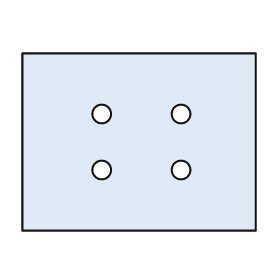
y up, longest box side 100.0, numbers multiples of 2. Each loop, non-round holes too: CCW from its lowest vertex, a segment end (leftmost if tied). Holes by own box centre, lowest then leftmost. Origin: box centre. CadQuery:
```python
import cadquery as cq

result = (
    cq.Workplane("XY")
    .moveTo(-50.0, -38.0)
    .lineTo(50.0, -38.0)
    .lineTo(50.0, 38.0)
    .lineTo(-50.0, 38.0)
    .close()
    .moveTo(-16.0, -12.0)
    .circle(4.0)
    .moveTo(18.0, -12.0)
    .circle(4.0)
    .moveTo(-16.0, 12.0)
    .circle(4.0)
    .moveTo(18.0, 12.0)
    .circle(4.0)
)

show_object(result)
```